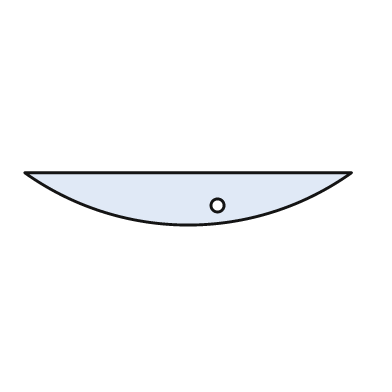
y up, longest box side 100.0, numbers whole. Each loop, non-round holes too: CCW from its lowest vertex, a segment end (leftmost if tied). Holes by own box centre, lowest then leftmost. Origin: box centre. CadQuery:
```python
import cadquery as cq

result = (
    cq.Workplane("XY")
    .moveTo(-50.0, 8.0)
    .threePointArc((0.0, -8.0), (50.0, 8.0))
    .close()
    .moveTo(9.0, -2.0)
    .circle(2.0)
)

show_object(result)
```